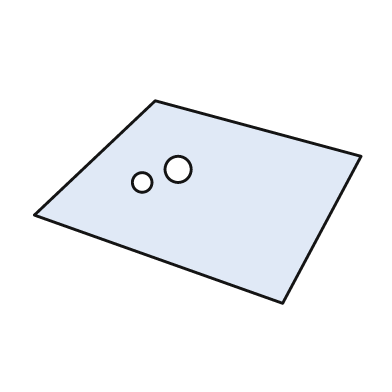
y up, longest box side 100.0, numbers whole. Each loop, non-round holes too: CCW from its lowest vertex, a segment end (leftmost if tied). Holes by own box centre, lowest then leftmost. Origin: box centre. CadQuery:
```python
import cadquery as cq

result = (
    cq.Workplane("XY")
    .moveTo(26.0, -31.0)
    .lineTo(50.0, 14.0)
    .lineTo(-13.0, 31.0)
    .lineTo(-50.0, -4.0)
    .close()
    .moveTo(-17.0, 6.0)
    .circle(3.0)
    .moveTo(-6.0, 10.0)
    .circle(4.0)
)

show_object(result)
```